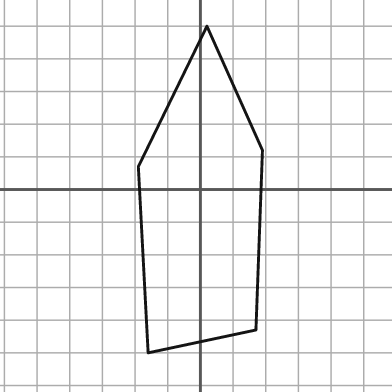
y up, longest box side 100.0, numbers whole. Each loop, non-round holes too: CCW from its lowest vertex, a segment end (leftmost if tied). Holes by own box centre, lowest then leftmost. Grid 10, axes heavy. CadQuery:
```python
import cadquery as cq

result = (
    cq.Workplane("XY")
    .moveTo(-16.0, -50.0)
    .lineTo(17.0, -43.0)
    .lineTo(19.0, 12.0)
    .lineTo(2.0, 50.0)
    .lineTo(-19.0, 7.0)
    .close()
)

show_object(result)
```